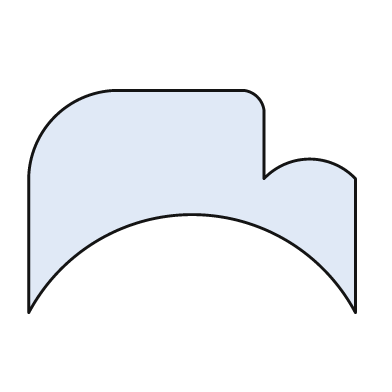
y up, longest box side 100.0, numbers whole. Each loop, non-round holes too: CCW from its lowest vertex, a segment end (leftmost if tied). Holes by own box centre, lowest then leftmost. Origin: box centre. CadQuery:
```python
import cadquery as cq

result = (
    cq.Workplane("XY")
    .moveTo(-50.0, -34.0)
    .threePointArc((0.0, -4.0), (50.0, -34.0))
    .lineTo(50.0, 7.0)
    .threePointArc((36.0, 13.0), (22.0, 7.0))
    .lineTo(22.0, 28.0)
    .threePointArc((20.0, 32.0), (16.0, 34.0))
    .lineTo(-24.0, 34.0)
    .threePointArc((-42.0, 26.0), (-50.0, 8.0))
    .close()
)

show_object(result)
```